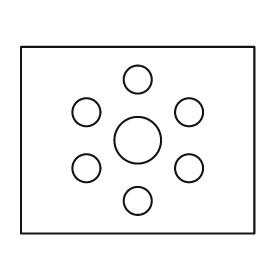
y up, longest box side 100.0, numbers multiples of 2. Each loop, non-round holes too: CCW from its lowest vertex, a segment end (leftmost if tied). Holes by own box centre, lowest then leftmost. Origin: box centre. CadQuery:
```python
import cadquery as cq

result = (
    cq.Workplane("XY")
    .moveTo(-50.0, -40.0)
    .lineTo(50.0, -40.0)
    .lineTo(50.0, 40.0)
    .lineTo(-50.0, 40.0)
    .close()
    .moveTo(0.0, -26.0)
    .circle(6.0)
    .moveTo(-22.0, -12.0)
    .circle(6.0)
    .moveTo(22.0, -12.0)
    .circle(6.0)
    .moveTo(0.0, 0.0)
    .circle(10.0)
    .moveTo(-22.0, 12.0)
    .circle(6.0)
    .moveTo(22.0, 12.0)
    .circle(6.0)
    .moveTo(0.0, 26.0)
    .circle(6.0)
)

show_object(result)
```